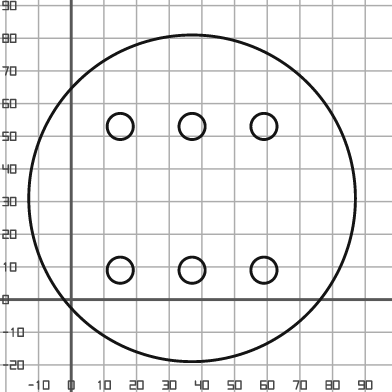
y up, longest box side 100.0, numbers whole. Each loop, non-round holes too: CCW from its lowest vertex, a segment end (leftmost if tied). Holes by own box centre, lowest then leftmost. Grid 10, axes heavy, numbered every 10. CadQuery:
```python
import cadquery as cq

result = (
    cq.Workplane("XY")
    .moveTo(37.0, 31.0)
    .circle(50.0)
    .moveTo(15.0, 9.0)
    .circle(4.0)
    .moveTo(37.0, 9.0)
    .circle(4.0)
    .moveTo(59.0, 9.0)
    .circle(4.0)
    .moveTo(15.0, 53.0)
    .circle(4.0)
    .moveTo(37.0, 53.0)
    .circle(4.0)
    .moveTo(59.0, 53.0)
    .circle(4.0)
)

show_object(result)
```